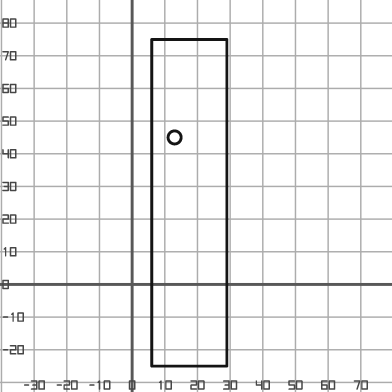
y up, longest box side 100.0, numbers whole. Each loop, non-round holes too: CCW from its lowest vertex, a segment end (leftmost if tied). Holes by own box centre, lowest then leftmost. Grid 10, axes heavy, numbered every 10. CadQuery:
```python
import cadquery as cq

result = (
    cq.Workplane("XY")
    .moveTo(6.0, -25.0)
    .lineTo(29.0, -25.0)
    .lineTo(29.0, 75.0)
    .lineTo(6.0, 75.0)
    .close()
    .moveTo(13.0, 45.0)
    .circle(2.0)
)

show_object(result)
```